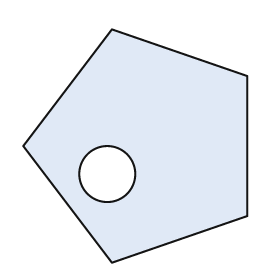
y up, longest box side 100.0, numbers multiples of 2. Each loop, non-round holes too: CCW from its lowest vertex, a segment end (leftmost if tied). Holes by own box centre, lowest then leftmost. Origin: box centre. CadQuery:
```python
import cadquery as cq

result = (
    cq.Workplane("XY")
    .moveTo(-10.0, -50.0)
    .lineTo(48.0, -30.0)
    .lineTo(48.0, 30.0)
    .lineTo(-10.0, 50.0)
    .lineTo(-48.0, 0.0)
    .close()
    .moveTo(-12.0, -12.0)
    .circle(12.0)
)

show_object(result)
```